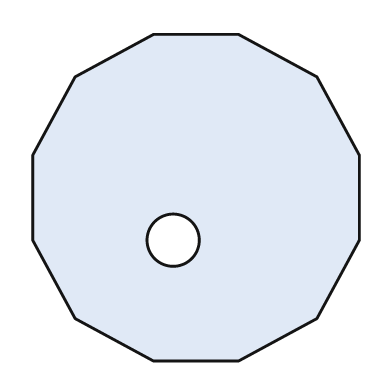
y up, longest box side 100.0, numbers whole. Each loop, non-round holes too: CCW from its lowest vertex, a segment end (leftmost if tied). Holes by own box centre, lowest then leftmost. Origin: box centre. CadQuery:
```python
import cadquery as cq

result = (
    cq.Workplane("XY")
    .moveTo(-13.0, -50.0)
    .lineTo(13.0, -50.0)
    .lineTo(37.0, -37.0)
    .lineTo(50.0, -13.0)
    .lineTo(50.0, 13.0)
    .lineTo(37.0, 37.0)
    .lineTo(13.0, 50.0)
    .lineTo(-13.0, 50.0)
    .lineTo(-37.0, 37.0)
    .lineTo(-50.0, 13.0)
    .lineTo(-50.0, -13.0)
    .lineTo(-37.0, -37.0)
    .close()
    .moveTo(-7.0, -13.0)
    .circle(8.0)
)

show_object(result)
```